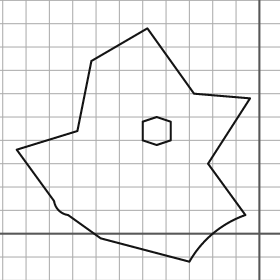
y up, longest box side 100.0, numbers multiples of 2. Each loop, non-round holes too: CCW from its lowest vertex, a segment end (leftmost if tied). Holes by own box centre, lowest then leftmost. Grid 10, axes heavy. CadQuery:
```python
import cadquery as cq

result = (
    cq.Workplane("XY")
    .moveTo(-30.0, -12.0)
    .threePointArc((-20.0, 0.0), (-6.0, 8.0))
    .lineTo(-22.0, 30.0)
    .lineTo(-4.0, 58.0)
    .lineTo(-28.0, 60.0)
    .lineTo(-48.0, 88.0)
    .lineTo(-72.0, 74.0)
    .lineTo(-78.0, 44.0)
    .lineTo(-104.0, 36.0)
    .lineTo(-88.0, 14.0)
    .threePointArc((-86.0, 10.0), (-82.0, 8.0))
    .lineTo(-68.0, -2.0)
    .close()
    .moveTo(-44.0, 38.0)
    .lineTo(-38.0, 40.0)
    .lineTo(-38.0, 48.0)
    .lineTo(-44.0, 50.0)
    .lineTo(-50.0, 48.0)
    .lineTo(-50.0, 40.0)
    .close()
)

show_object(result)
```